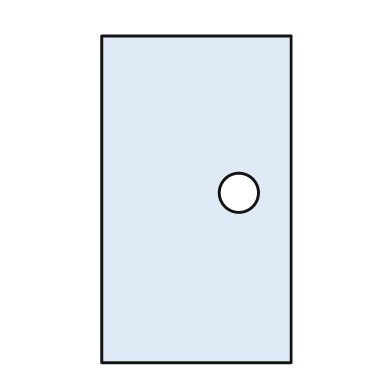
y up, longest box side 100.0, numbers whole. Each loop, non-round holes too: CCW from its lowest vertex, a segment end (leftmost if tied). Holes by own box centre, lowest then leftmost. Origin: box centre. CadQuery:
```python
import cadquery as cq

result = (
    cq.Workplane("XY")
    .moveTo(-29.0, -50.0)
    .lineTo(29.0, -50.0)
    .lineTo(29.0, 50.0)
    .lineTo(-29.0, 50.0)
    .close()
    .moveTo(13.0, 2.0)
    .circle(6.0)
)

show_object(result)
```